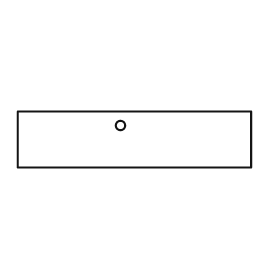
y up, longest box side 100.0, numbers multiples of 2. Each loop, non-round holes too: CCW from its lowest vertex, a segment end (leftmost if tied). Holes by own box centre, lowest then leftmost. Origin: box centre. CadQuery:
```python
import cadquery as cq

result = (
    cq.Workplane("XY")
    .moveTo(-50.0, -12.0)
    .lineTo(50.0, -12.0)
    .lineTo(50.0, 12.0)
    .lineTo(-50.0, 12.0)
    .close()
    .moveTo(-6.0, 6.0)
    .circle(2.0)
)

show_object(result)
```